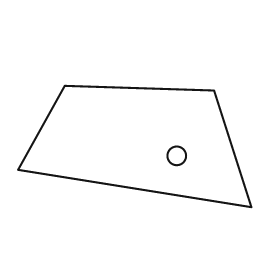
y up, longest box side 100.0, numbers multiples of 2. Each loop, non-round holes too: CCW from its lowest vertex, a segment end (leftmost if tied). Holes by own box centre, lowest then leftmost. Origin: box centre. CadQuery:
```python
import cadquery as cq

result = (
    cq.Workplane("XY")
    .moveTo(50.0, -26.0)
    .lineTo(34.0, 24.0)
    .lineTo(-30.0, 26.0)
    .lineTo(-50.0, -10.0)
    .close()
    .moveTo(18.0, -4.0)
    .circle(4.0)
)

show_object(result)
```